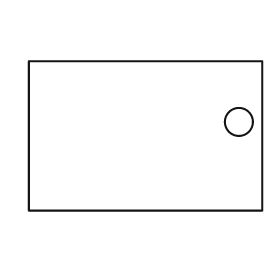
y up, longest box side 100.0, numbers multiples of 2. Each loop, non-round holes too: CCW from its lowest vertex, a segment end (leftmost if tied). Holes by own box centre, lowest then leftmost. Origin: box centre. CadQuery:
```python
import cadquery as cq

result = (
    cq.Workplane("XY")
    .moveTo(-50.0, -32.0)
    .lineTo(50.0, -32.0)
    .lineTo(50.0, 32.0)
    .lineTo(-50.0, 32.0)
    .close()
    .moveTo(40.0, 6.0)
    .circle(6.0)
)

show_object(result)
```